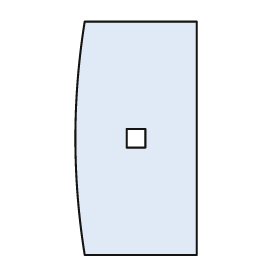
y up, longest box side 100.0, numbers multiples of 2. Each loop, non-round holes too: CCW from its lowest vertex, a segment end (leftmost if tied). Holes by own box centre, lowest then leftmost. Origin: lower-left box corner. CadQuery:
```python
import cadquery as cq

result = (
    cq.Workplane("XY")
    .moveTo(4.0, 0.0)
    .lineTo(52.0, 0.0)
    .lineTo(52.0, 100.0)
    .lineTo(4.0, 100.0)
    .threePointArc((0.0, 50.0), (4.0, 0.0))
    .close()
    .moveTo(22.0, 46.0)
    .lineTo(30.0, 46.0)
    .lineTo(30.0, 54.0)
    .lineTo(22.0, 54.0)
    .close()
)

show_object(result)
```